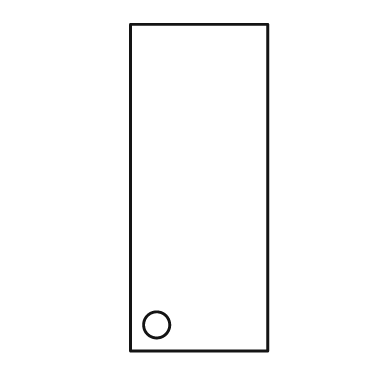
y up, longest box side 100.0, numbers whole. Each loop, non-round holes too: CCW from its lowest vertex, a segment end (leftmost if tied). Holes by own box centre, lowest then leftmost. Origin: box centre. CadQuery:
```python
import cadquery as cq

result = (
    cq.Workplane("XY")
    .moveTo(-21.0, -50.0)
    .lineTo(21.0, -50.0)
    .lineTo(21.0, 50.0)
    .lineTo(-21.0, 50.0)
    .close()
    .moveTo(-13.0, -42.0)
    .circle(4.0)
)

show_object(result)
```